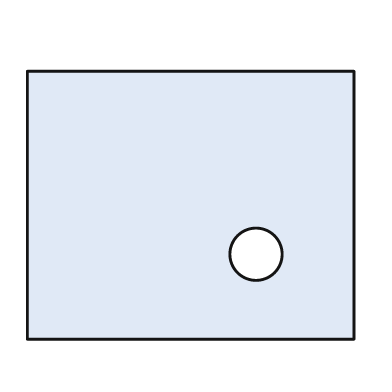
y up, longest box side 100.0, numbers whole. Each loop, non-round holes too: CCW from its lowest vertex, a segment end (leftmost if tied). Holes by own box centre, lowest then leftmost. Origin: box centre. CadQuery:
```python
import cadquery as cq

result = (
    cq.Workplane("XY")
    .moveTo(-50.0, -41.0)
    .lineTo(50.0, -41.0)
    .lineTo(50.0, 41.0)
    .lineTo(-50.0, 41.0)
    .close()
    .moveTo(20.0, -15.0)
    .circle(8.0)
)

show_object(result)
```